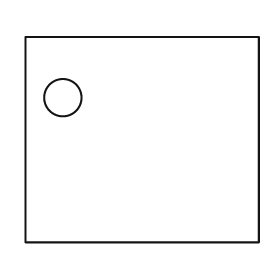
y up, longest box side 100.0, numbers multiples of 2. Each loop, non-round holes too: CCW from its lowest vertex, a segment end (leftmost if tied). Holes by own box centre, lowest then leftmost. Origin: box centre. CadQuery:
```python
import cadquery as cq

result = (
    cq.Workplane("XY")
    .moveTo(-50.0, -44.0)
    .lineTo(50.0, -44.0)
    .lineTo(50.0, 44.0)
    .lineTo(-50.0, 44.0)
    .close()
    .moveTo(-34.0, 18.0)
    .circle(8.0)
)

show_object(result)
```